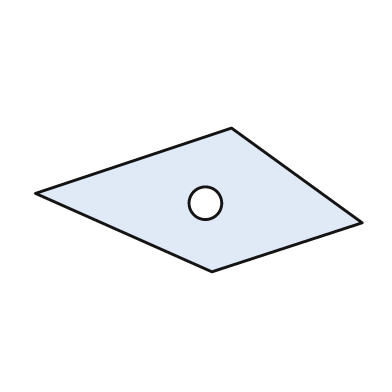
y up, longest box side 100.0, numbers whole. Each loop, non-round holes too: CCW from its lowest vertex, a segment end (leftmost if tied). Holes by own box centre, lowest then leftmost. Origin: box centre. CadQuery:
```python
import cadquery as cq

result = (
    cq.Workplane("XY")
    .moveTo(4.0, -22.0)
    .lineTo(50.0, -7.0)
    .lineTo(10.0, 22.0)
    .lineTo(-50.0, 2.0)
    .close()
    .moveTo(2.0, -1.0)
    .circle(5.0)
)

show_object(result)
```